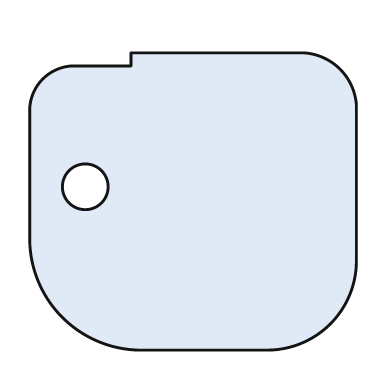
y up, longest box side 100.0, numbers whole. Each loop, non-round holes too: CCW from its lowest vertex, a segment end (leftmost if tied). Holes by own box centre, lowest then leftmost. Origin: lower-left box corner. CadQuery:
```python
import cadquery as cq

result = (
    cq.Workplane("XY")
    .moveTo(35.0, 0.0)
    .lineTo(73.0, 0.0)
    .threePointArc((92.0, 8.0), (100.0, 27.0))
    .lineTo(100.0, 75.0)
    .threePointArc((95.0, 86.0), (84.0, 91.0))
    .lineTo(31.0, 91.0)
    .lineTo(31.0, 87.0)
    .lineTo(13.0, 87.0)
    .threePointArc((4.0, 83.0), (0.0, 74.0))
    .lineTo(0.0, 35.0)
    .threePointArc((10.0, 10.0), (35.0, 0.0))
    .close()
    .moveTo(17.0, 50.0)
    .circle(7.0)
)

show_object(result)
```